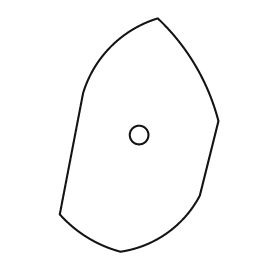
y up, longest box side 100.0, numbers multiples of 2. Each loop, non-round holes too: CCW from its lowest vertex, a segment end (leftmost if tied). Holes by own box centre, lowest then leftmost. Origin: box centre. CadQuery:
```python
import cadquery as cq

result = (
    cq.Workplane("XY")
    .moveTo(-8.0, -50.0)
    .threePointArc((12.0, -42.0), (26.0, -26.0))
    .lineTo(34.0, 6.0)
    .threePointArc((24.0, 30.0), (8.0, 50.0))
    .threePointArc((-12.0, 38.0), (-24.0, 18.0))
    .lineTo(-34.0, -34.0)
    .threePointArc((-22.0, -44.0), (-8.0, -50.0))
    .close()
    .moveTo(0.0, 0.0)
    .circle(4.0)
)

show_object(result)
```